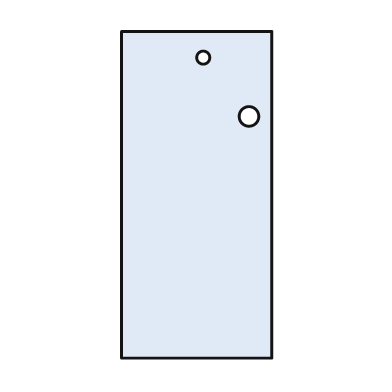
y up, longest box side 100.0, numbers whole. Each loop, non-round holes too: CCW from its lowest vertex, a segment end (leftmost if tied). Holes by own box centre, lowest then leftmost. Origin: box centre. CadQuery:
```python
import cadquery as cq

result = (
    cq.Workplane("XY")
    .moveTo(-23.0, -50.0)
    .lineTo(23.0, -50.0)
    .lineTo(23.0, 50.0)
    .lineTo(-23.0, 50.0)
    .close()
    .moveTo(16.0, 24.0)
    .circle(3.0)
    .moveTo(2.0, 42.0)
    .circle(2.0)
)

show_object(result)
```